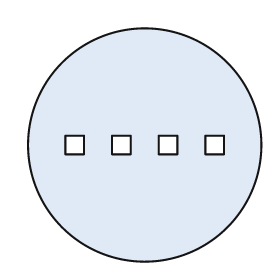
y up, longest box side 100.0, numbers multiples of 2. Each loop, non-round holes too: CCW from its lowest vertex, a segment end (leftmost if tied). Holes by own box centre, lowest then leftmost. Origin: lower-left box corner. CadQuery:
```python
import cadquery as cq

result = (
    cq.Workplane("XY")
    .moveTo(50.0, 50.0)
    .circle(50.0)
    .moveTo(16.0, 46.0)
    .lineTo(24.0, 46.0)
    .lineTo(24.0, 54.0)
    .lineTo(16.0, 54.0)
    .close()
    .moveTo(36.0, 46.0)
    .lineTo(44.0, 46.0)
    .lineTo(44.0, 54.0)
    .lineTo(36.0, 54.0)
    .close()
    .moveTo(56.0, 46.0)
    .lineTo(64.0, 46.0)
    .lineTo(64.0, 54.0)
    .lineTo(56.0, 54.0)
    .close()
    .moveTo(76.0, 46.0)
    .lineTo(84.0, 46.0)
    .lineTo(84.0, 54.0)
    .lineTo(76.0, 54.0)
    .close()
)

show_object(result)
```